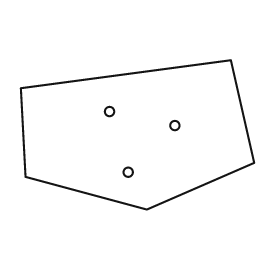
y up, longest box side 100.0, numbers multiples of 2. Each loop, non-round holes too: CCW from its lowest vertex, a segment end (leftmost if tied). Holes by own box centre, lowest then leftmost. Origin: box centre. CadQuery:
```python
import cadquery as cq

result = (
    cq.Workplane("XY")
    .moveTo(4.0, -32.0)
    .lineTo(50.0, -12.0)
    .lineTo(40.0, 32.0)
    .lineTo(-50.0, 20.0)
    .lineTo(-48.0, -18.0)
    .close()
    .moveTo(-4.0, -16.0)
    .circle(2.0)
    .moveTo(16.0, 4.0)
    .circle(2.0)
    .moveTo(-12.0, 10.0)
    .circle(2.0)
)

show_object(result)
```